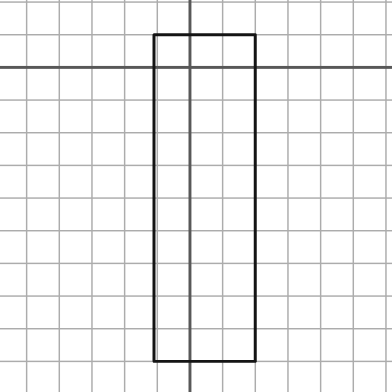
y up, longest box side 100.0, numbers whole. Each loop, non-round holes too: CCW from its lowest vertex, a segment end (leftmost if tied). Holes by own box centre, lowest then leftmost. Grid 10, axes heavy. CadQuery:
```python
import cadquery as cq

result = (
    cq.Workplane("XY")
    .moveTo(-11.0, -90.0)
    .lineTo(20.0, -90.0)
    .lineTo(20.0, 10.0)
    .lineTo(-11.0, 10.0)
    .close()
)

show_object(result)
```